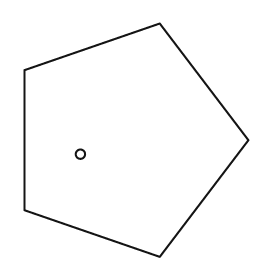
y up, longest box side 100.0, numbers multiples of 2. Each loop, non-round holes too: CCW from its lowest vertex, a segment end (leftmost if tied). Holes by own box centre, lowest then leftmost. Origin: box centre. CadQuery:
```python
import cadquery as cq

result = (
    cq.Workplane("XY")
    .moveTo(10.0, -50.0)
    .lineTo(48.0, 0.0)
    .lineTo(10.0, 50.0)
    .lineTo(-48.0, 30.0)
    .lineTo(-48.0, -30.0)
    .close()
    .moveTo(-24.0, -6.0)
    .circle(2.0)
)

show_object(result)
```